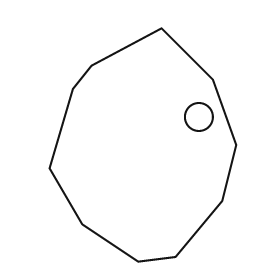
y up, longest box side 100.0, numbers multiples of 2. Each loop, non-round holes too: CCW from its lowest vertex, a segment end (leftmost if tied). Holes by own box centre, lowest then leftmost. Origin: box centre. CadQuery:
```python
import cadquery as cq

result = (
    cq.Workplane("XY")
    .moveTo(-2.0, -50.0)
    .lineTo(14.0, -48.0)
    .lineTo(34.0, -24.0)
    .lineTo(40.0, 0.0)
    .lineTo(30.0, 28.0)
    .lineTo(8.0, 50.0)
    .lineTo(-22.0, 34.0)
    .lineTo(-30.0, 24.0)
    .lineTo(-40.0, -10.0)
    .lineTo(-26.0, -34.0)
    .close()
    .moveTo(24.0, 12.0)
    .circle(6.0)
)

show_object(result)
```